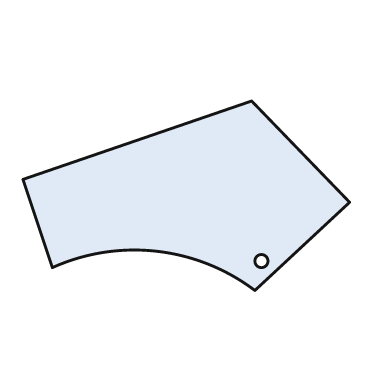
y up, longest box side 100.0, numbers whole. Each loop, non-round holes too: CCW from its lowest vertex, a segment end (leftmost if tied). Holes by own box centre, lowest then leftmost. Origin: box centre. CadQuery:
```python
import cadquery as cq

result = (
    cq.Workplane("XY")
    .moveTo(21.0, -29.0)
    .lineTo(50.0, -2.0)
    .lineTo(20.0, 29.0)
    .lineTo(-50.0, 5.0)
    .lineTo(-41.0, -22.0)
    .threePointArc((-9.0, -17.0), (21.0, -29.0))
    .close()
    .moveTo(23.0, -20.0)
    .circle(2.0)
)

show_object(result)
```